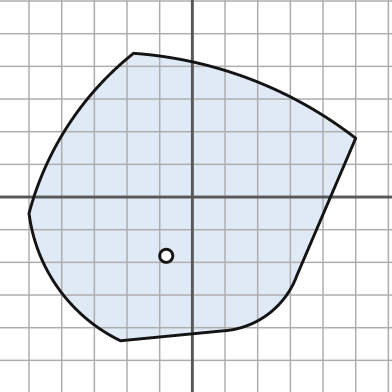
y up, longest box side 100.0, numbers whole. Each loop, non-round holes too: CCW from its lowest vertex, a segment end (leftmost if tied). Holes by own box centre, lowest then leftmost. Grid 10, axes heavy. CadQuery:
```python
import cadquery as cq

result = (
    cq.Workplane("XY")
    .moveTo(-22.0, -44.0)
    .lineTo(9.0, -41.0)
    .threePointArc((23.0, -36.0), (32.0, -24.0))
    .lineTo(50.0, 18.0)
    .threePointArc((18.0, 36.0), (-18.0, 44.0))
    .threePointArc((-38.0, 22.0), (-50.0, -5.0))
    .threePointArc((-41.0, -28.0), (-22.0, -44.0))
    .close()
    .moveTo(-8.0, -18.0)
    .circle(2.0)
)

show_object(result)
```